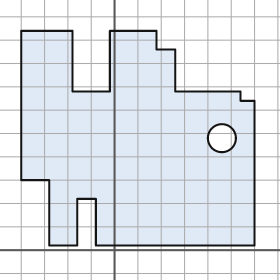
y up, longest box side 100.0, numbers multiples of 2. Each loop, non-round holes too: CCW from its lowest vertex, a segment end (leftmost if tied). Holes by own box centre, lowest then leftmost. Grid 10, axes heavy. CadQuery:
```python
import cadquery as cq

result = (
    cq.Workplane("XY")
    .moveTo(-28.0, 2.0)
    .lineTo(-16.0, 2.0)
    .lineTo(-16.0, 22.0)
    .lineTo(-8.0, 22.0)
    .lineTo(-8.0, 2.0)
    .lineTo(60.0, 2.0)
    .lineTo(60.0, 64.0)
    .lineTo(54.0, 64.0)
    .lineTo(54.0, 68.0)
    .lineTo(26.0, 68.0)
    .lineTo(26.0, 86.0)
    .lineTo(18.0, 86.0)
    .lineTo(18.0, 94.0)
    .lineTo(-2.0, 94.0)
    .lineTo(-2.0, 68.0)
    .lineTo(-18.0, 68.0)
    .lineTo(-18.0, 94.0)
    .lineTo(-40.0, 94.0)
    .lineTo(-40.0, 30.0)
    .lineTo(-28.0, 30.0)
    .close()
    .moveTo(46.0, 48.0)
    .circle(6.0)
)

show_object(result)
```